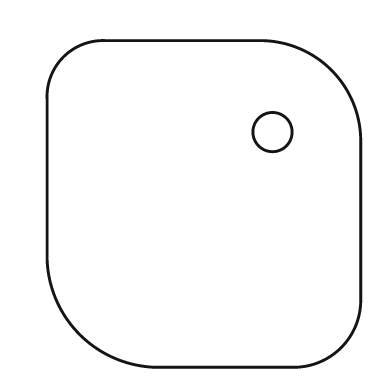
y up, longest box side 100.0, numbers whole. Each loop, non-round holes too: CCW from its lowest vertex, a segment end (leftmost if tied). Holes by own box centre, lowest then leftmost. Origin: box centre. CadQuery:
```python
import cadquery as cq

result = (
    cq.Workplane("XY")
    .moveTo(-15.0, -50.0)
    .lineTo(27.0, -50.0)
    .threePointArc((42.0, -44.0), (48.0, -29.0))
    .lineTo(48.0, 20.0)
    .threePointArc((39.0, 41.0), (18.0, 50.0))
    .lineTo(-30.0, 50.0)
    .threePointArc((-43.0, 45.0), (-48.0, 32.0))
    .lineTo(-48.0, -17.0)
    .threePointArc((-38.0, -40.0), (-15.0, -50.0))
    .close()
    .moveTo(21.0, 22.0)
    .circle(6.0)
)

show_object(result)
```